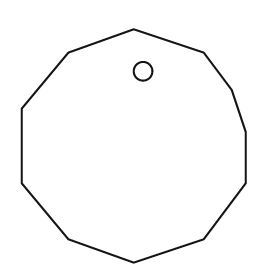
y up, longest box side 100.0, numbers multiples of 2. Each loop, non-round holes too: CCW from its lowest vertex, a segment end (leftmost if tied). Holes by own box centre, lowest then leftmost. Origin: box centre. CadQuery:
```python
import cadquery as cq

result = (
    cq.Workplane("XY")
    .moveTo(0.0, -50.0)
    .lineTo(30.0, -40.0)
    .lineTo(48.0, -16.0)
    .lineTo(48.0, 6.0)
    .lineTo(42.0, 24.0)
    .lineTo(30.0, 40.0)
    .lineTo(0.0, 50.0)
    .lineTo(-28.0, 40.0)
    .lineTo(-48.0, 16.0)
    .lineTo(-48.0, -16.0)
    .lineTo(-28.0, -40.0)
    .close()
    .moveTo(4.0, 32.0)
    .circle(4.0)
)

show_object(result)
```